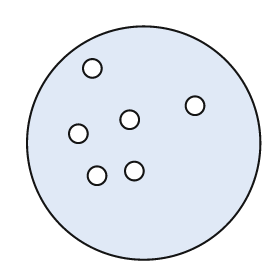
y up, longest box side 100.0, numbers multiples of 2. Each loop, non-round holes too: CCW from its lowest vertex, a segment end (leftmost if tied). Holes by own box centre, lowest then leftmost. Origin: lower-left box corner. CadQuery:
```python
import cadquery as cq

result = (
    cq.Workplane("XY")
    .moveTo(50.0, 50.0)
    .circle(50.0)
    .moveTo(30.0, 36.0)
    .circle(4.0)
    .moveTo(46.0, 38.0)
    .circle(4.0)
    .moveTo(22.0, 54.0)
    .circle(4.0)
    .moveTo(44.0, 60.0)
    .circle(4.0)
    .moveTo(72.0, 66.0)
    .circle(4.0)
    .moveTo(28.0, 82.0)
    .circle(4.0)
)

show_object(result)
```